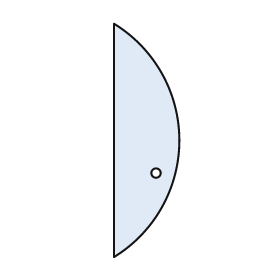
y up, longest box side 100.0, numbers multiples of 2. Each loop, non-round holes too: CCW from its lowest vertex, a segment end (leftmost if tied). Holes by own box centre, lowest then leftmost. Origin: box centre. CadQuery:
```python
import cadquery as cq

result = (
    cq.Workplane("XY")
    .moveTo(-14.0, -50.0)
    .threePointArc((14.0, 0.0), (-14.0, 50.0))
    .close()
    .moveTo(4.0, -14.0)
    .circle(2.0)
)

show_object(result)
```